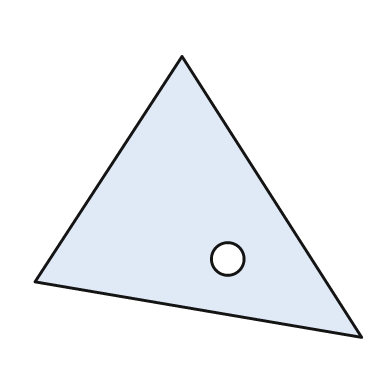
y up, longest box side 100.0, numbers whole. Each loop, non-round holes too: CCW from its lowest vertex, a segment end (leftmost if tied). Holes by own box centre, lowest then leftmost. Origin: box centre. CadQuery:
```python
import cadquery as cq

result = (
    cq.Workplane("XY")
    .moveTo(50.0, -43.0)
    .lineTo(-5.0, 43.0)
    .lineTo(-50.0, -26.0)
    .close()
    .moveTo(9.0, -19.0)
    .circle(5.0)
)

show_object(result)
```